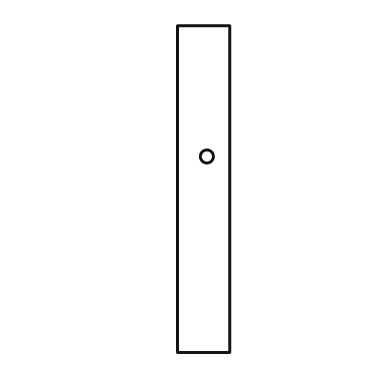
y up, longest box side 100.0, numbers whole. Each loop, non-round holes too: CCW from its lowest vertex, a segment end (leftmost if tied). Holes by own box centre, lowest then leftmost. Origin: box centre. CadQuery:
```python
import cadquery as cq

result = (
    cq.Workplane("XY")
    .moveTo(-8.0, -50.0)
    .lineTo(8.0, -50.0)
    .lineTo(8.0, 50.0)
    .lineTo(-8.0, 50.0)
    .close()
    .moveTo(1.0, 10.0)
    .circle(2.0)
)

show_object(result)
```